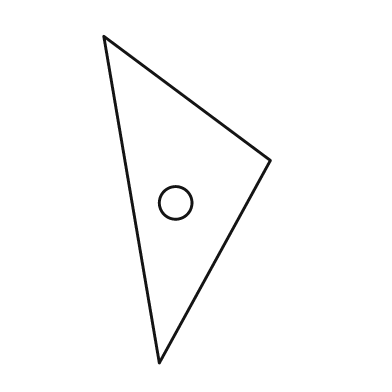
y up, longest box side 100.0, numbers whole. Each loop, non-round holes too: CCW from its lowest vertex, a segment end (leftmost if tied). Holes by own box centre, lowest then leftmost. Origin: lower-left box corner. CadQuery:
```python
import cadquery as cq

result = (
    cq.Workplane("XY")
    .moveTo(17.0, 0.0)
    .lineTo(51.0, 62.0)
    .lineTo(0.0, 100.0)
    .close()
    .moveTo(22.0, 49.0)
    .circle(5.0)
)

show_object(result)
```